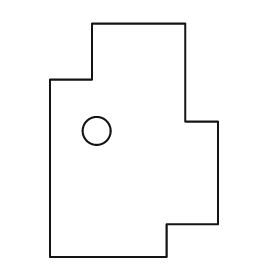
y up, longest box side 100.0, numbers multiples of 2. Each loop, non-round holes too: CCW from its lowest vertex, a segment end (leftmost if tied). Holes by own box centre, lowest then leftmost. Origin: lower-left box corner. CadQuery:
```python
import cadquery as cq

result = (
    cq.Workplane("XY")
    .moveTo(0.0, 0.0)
    .lineTo(50.0, 0.0)
    .lineTo(50.0, 14.0)
    .lineTo(72.0, 14.0)
    .lineTo(72.0, 58.0)
    .lineTo(58.0, 58.0)
    .lineTo(58.0, 100.0)
    .lineTo(18.0, 100.0)
    .lineTo(18.0, 76.0)
    .lineTo(0.0, 76.0)
    .close()
    .moveTo(20.0, 54.0)
    .circle(6.0)
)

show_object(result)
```